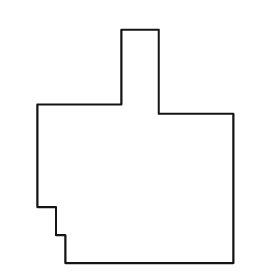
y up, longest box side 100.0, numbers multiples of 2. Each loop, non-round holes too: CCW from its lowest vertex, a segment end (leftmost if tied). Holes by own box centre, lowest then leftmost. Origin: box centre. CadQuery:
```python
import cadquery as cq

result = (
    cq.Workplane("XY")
    .moveTo(-30.0, -50.0)
    .lineTo(42.0, -50.0)
    .lineTo(42.0, 14.0)
    .lineTo(10.0, 14.0)
    .lineTo(10.0, 50.0)
    .lineTo(-6.0, 50.0)
    .lineTo(-6.0, 18.0)
    .lineTo(-42.0, 18.0)
    .lineTo(-42.0, -26.0)
    .lineTo(-34.0, -26.0)
    .lineTo(-34.0, -38.0)
    .lineTo(-30.0, -38.0)
    .close()
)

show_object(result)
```